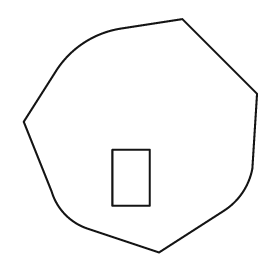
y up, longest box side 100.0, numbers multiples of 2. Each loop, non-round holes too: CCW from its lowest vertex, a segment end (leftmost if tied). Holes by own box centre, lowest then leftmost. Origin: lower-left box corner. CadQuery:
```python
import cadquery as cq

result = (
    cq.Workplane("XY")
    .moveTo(58.0, 0.0)
    .lineTo(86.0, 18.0)
    .threePointArc((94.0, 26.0), (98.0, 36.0))
    .lineTo(100.0, 68.0)
    .lineTo(68.0, 100.0)
    .lineTo(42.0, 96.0)
    .threePointArc((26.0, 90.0), (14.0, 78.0))
    .lineTo(0.0, 56.0)
    .lineTo(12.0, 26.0)
    .threePointArc((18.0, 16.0), (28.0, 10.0))
    .close()
    .moveTo(38.0, 20.0)
    .lineTo(54.0, 20.0)
    .lineTo(54.0, 44.0)
    .lineTo(38.0, 44.0)
    .close()
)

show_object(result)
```